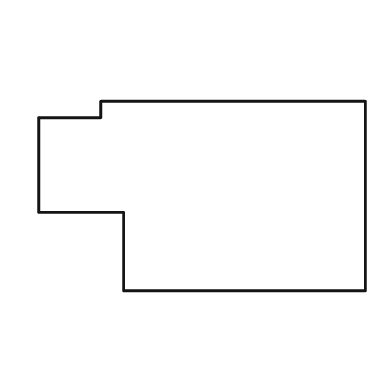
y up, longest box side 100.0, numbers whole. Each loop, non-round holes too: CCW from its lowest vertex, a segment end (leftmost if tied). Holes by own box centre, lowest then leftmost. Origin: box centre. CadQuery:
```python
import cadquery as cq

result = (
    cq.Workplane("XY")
    .moveTo(-24.0, -29.0)
    .lineTo(50.0, -29.0)
    .lineTo(50.0, 29.0)
    .lineTo(-31.0, 29.0)
    .lineTo(-31.0, 24.0)
    .lineTo(-50.0, 24.0)
    .lineTo(-50.0, -5.0)
    .lineTo(-24.0, -5.0)
    .close()
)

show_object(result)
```